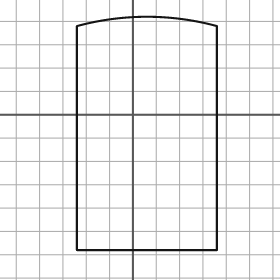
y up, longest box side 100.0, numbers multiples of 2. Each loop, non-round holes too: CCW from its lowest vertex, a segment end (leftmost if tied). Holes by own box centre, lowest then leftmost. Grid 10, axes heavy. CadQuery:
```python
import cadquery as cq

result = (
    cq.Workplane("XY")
    .moveTo(-24.0, -58.0)
    .lineTo(36.0, -58.0)
    .lineTo(36.0, 38.0)
    .threePointArc((6.0, 42.0), (-24.0, 38.0))
    .close()
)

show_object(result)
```